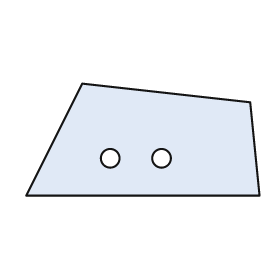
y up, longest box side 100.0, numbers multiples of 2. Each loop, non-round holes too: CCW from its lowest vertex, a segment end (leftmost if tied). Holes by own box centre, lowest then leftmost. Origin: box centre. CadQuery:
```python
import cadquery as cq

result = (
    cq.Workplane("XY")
    .moveTo(-50.0, -24.0)
    .lineTo(50.0, -24.0)
    .lineTo(46.0, 16.0)
    .lineTo(-26.0, 24.0)
    .close()
    .moveTo(-14.0, -8.0)
    .circle(4.0)
    .moveTo(8.0, -8.0)
    .circle(4.0)
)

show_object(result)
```